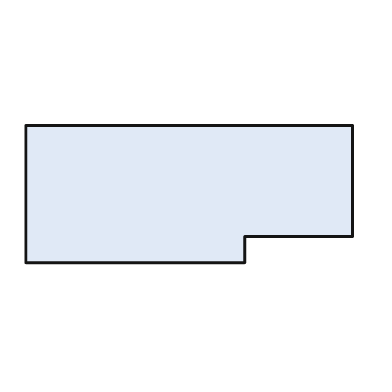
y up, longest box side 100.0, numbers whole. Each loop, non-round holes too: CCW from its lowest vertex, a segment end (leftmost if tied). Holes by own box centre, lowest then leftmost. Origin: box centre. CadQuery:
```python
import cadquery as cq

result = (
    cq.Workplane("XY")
    .moveTo(-50.0, -21.0)
    .lineTo(17.0, -21.0)
    .lineTo(17.0, -13.0)
    .lineTo(50.0, -13.0)
    .lineTo(50.0, 21.0)
    .lineTo(-50.0, 21.0)
    .close()
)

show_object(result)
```